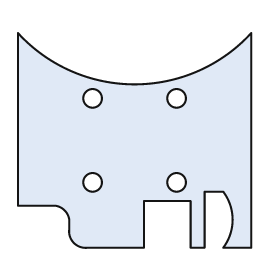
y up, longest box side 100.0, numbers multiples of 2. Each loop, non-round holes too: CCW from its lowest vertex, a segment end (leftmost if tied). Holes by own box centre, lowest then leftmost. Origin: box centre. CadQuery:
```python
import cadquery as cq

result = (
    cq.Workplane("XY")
    .moveTo(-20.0, -46.0)
    .lineTo(4.0, -46.0)
    .lineTo(4.0, -26.0)
    .lineTo(24.0, -26.0)
    .lineTo(24.0, -46.0)
    .lineTo(30.0, -46.0)
    .lineTo(30.0, -22.0)
    .lineTo(38.0, -22.0)
    .threePointArc((42.0, -34.0), (38.0, -46.0))
    .lineTo(50.0, -46.0)
    .lineTo(50.0, 46.0)
    .threePointArc((0.0, 24.0), (-50.0, 46.0))
    .lineTo(-50.0, -28.0)
    .lineTo(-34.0, -28.0)
    .threePointArc((-30.0, -30.0), (-28.0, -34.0))
    .lineTo(-28.0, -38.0)
    .threePointArc((-26.0, -44.0), (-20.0, -46.0))
    .close()
    .moveTo(-18.0, -18.0)
    .circle(4.0)
    .moveTo(18.0, -18.0)
    .circle(4.0)
    .moveTo(-18.0, 18.0)
    .circle(4.0)
    .moveTo(18.0, 18.0)
    .circle(4.0)
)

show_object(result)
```